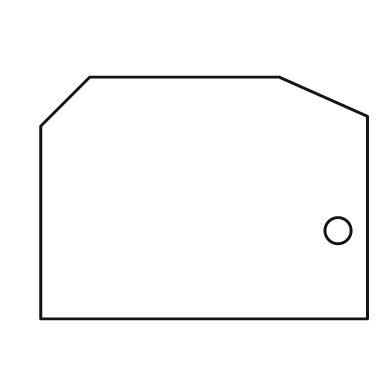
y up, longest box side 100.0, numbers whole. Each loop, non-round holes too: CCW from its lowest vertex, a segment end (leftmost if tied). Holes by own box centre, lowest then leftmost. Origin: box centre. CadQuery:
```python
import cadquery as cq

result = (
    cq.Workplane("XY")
    .moveTo(-50.0, -37.0)
    .lineTo(50.0, -37.0)
    .lineTo(50.0, 25.0)
    .lineTo(23.0, 37.0)
    .lineTo(-35.0, 37.0)
    .lineTo(-50.0, 22.0)
    .close()
    .moveTo(41.0, -10.0)
    .circle(4.0)
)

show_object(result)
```